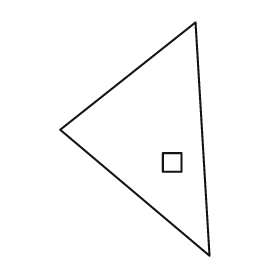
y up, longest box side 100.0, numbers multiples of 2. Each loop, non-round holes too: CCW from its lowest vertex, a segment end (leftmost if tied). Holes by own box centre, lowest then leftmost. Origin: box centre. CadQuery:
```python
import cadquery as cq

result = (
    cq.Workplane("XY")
    .moveTo(32.0, -50.0)
    .lineTo(26.0, 50.0)
    .lineTo(-32.0, 4.0)
    .close()
    .moveTo(12.0, -14.0)
    .lineTo(20.0, -14.0)
    .lineTo(20.0, -6.0)
    .lineTo(12.0, -6.0)
    .close()
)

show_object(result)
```